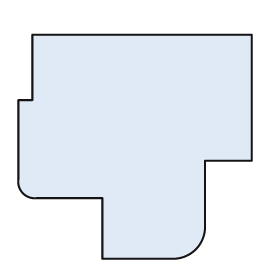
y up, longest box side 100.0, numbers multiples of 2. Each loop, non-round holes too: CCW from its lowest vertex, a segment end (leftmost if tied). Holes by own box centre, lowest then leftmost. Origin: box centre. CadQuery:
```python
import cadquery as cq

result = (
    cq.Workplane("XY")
    .moveTo(-14.0, -48.0)
    .lineTo(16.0, -48.0)
    .threePointArc((26.0, -44.0), (30.0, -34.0))
    .lineTo(30.0, -6.0)
    .lineTo(50.0, -6.0)
    .lineTo(50.0, 48.0)
    .lineTo(-44.0, 48.0)
    .lineTo(-44.0, 20.0)
    .lineTo(-50.0, 20.0)
    .lineTo(-50.0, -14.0)
    .threePointArc((-48.0, -20.0), (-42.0, -22.0))
    .lineTo(-14.0, -22.0)
    .close()
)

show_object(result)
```